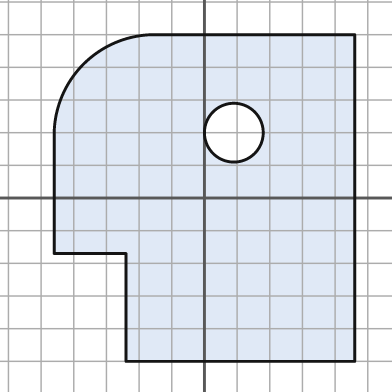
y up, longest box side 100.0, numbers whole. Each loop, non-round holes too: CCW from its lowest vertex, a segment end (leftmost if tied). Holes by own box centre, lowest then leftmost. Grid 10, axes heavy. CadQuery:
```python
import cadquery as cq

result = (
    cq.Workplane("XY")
    .moveTo(-24.0, -50.0)
    .lineTo(46.0, -50.0)
    .lineTo(46.0, 50.0)
    .lineTo(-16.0, 50.0)
    .threePointArc((-37.0, 41.0), (-46.0, 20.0))
    .lineTo(-46.0, -17.0)
    .lineTo(-24.0, -17.0)
    .close()
    .moveTo(9.0, 20.0)
    .circle(9.0)
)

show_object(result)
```